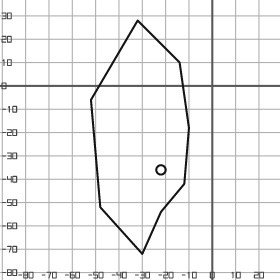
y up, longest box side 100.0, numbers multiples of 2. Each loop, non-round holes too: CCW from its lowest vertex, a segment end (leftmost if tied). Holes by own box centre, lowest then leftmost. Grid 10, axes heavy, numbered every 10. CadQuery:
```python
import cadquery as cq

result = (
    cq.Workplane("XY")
    .moveTo(-30.0, -72.0)
    .lineTo(-22.0, -54.0)
    .lineTo(-12.0, -42.0)
    .lineTo(-10.0, -18.0)
    .lineTo(-14.0, 10.0)
    .lineTo(-32.0, 28.0)
    .lineTo(-52.0, -6.0)
    .lineTo(-48.0, -52.0)
    .close()
    .moveTo(-22.0, -36.0)
    .circle(2.0)
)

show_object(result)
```